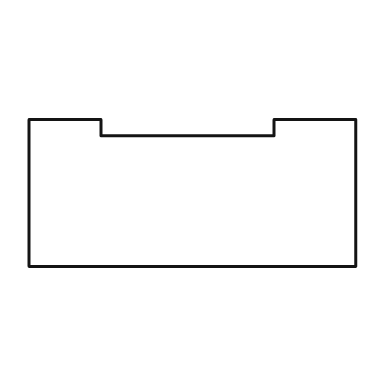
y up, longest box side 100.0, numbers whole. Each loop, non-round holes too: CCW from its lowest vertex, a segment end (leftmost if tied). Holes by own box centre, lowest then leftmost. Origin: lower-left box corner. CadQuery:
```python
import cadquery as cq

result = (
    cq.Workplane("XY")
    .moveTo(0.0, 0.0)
    .lineTo(100.0, 0.0)
    .lineTo(100.0, 45.0)
    .lineTo(75.0, 45.0)
    .lineTo(75.0, 40.0)
    .lineTo(22.0, 40.0)
    .lineTo(22.0, 45.0)
    .lineTo(0.0, 45.0)
    .close()
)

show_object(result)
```